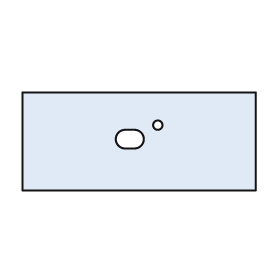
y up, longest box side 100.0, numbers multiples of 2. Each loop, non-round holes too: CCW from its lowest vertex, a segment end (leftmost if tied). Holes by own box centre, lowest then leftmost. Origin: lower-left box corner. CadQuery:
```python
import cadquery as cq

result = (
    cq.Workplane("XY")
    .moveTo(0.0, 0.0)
    .lineTo(100.0, 0.0)
    .lineTo(100.0, 42.0)
    .lineTo(0.0, 42.0)
    .close()
    .moveTo(44.0, 18.0)
    .lineTo(48.0, 18.0)
    .threePointArc((52.0, 22.0), (48.0, 26.0))
    .lineTo(44.0, 26.0)
    .threePointArc((40.0, 22.0), (44.0, 18.0))
    .close()
    .moveTo(58.0, 28.0)
    .circle(2.0)
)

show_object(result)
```